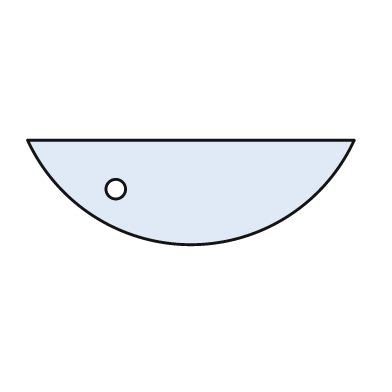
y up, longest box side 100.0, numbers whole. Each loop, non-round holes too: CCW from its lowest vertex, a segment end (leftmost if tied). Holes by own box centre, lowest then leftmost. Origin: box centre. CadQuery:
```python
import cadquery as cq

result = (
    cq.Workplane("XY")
    .moveTo(-50.0, 16.0)
    .threePointArc((0.0, -16.0), (50.0, 16.0))
    .close()
    .moveTo(-23.0, 1.0)
    .circle(3.0)
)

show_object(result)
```